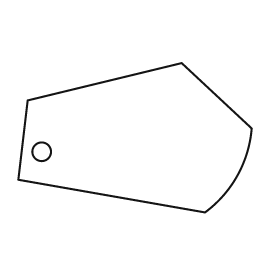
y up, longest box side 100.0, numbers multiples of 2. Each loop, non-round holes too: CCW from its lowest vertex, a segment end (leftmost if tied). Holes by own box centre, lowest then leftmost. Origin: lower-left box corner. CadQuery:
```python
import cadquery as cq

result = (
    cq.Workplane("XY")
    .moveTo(80.0, 0.0)
    .threePointArc((94.0, 16.0), (100.0, 36.0))
    .lineTo(70.0, 64.0)
    .lineTo(4.0, 48.0)
    .lineTo(0.0, 14.0)
    .close()
    .moveTo(10.0, 26.0)
    .circle(4.0)
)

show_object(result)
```